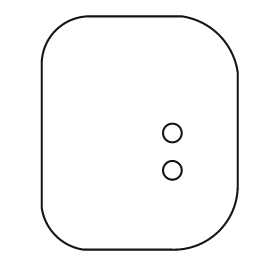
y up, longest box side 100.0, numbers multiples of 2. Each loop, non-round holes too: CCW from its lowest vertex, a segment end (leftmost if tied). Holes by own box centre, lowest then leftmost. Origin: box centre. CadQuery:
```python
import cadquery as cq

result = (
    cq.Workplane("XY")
    .moveTo(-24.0, -50.0)
    .lineTo(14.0, -50.0)
    .threePointArc((34.0, -42.0), (42.0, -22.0))
    .lineTo(42.0, 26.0)
    .threePointArc((34.0, 42.0), (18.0, 50.0))
    .lineTo(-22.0, 50.0)
    .threePointArc((-36.0, 44.0), (-42.0, 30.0))
    .lineTo(-42.0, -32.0)
    .threePointArc((-36.0, -44.0), (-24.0, -50.0))
    .close()
    .moveTo(14.0, -16.0)
    .circle(4.0)
    .moveTo(14.0, 0.0)
    .circle(4.0)
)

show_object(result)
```